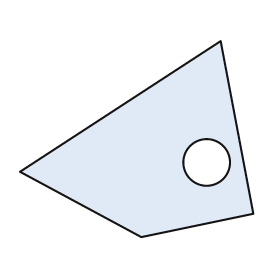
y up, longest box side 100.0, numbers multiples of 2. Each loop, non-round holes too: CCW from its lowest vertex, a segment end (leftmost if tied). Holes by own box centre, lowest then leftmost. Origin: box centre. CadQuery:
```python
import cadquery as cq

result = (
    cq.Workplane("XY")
    .moveTo(2.0, -42.0)
    .lineTo(50.0, -32.0)
    .lineTo(36.0, 42.0)
    .lineTo(-50.0, -14.0)
    .close()
    .moveTo(30.0, -10.0)
    .circle(10.0)
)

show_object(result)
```